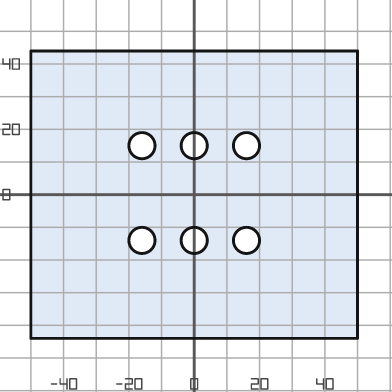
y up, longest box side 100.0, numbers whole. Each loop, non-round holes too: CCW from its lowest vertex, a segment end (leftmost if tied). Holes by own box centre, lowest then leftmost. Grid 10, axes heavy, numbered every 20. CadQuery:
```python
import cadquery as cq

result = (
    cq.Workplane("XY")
    .moveTo(-50.0, -44.0)
    .lineTo(50.0, -44.0)
    .lineTo(50.0, 44.0)
    .lineTo(-50.0, 44.0)
    .close()
    .moveTo(-16.0, -14.0)
    .circle(4.0)
    .moveTo(0.0, -14.0)
    .circle(4.0)
    .moveTo(16.0, -14.0)
    .circle(4.0)
    .moveTo(-16.0, 15.0)
    .circle(4.0)
    .moveTo(0.0, 15.0)
    .circle(4.0)
    .moveTo(16.0, 15.0)
    .circle(4.0)
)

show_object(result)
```